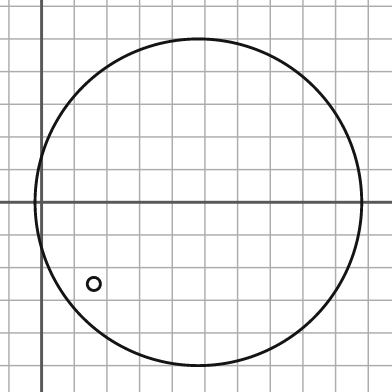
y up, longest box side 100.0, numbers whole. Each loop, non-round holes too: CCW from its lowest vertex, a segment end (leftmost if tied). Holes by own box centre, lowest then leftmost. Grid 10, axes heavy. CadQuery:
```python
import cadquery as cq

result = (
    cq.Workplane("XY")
    .moveTo(48.0, 0.0)
    .circle(50.0)
    .moveTo(16.0, -25.0)
    .circle(2.0)
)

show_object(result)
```